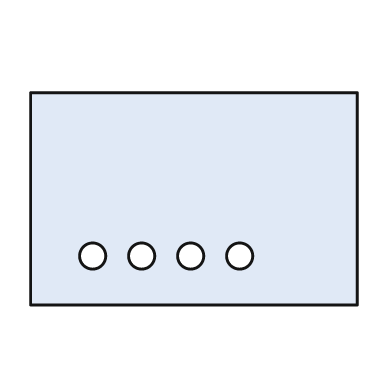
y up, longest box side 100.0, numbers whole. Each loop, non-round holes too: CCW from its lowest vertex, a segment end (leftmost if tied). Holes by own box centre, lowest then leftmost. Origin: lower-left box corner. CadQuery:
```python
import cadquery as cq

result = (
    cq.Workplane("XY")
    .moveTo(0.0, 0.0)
    .lineTo(100.0, 0.0)
    .lineTo(100.0, 65.0)
    .lineTo(0.0, 65.0)
    .close()
    .moveTo(19.0, 15.0)
    .circle(4.0)
    .moveTo(34.0, 15.0)
    .circle(4.0)
    .moveTo(49.0, 15.0)
    .circle(4.0)
    .moveTo(64.0, 15.0)
    .circle(4.0)
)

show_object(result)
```